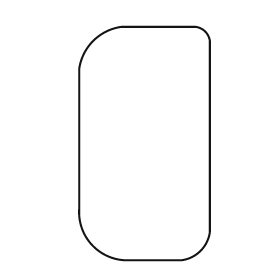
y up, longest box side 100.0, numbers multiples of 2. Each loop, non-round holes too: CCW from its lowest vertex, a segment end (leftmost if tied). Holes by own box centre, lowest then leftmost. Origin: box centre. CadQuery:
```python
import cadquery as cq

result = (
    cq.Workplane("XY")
    .moveTo(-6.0, -50.0)
    .lineTo(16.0, -50.0)
    .threePointArc((24.0, -46.0), (28.0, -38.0))
    .lineTo(28.0, 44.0)
    .threePointArc((26.0, 48.0), (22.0, 50.0))
    .lineTo(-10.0, 50.0)
    .threePointArc((-22.0, 44.0), (-28.0, 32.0))
    .lineTo(-28.0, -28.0)
    .threePointArc((-22.0, -44.0), (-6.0, -50.0))
    .close()
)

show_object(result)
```